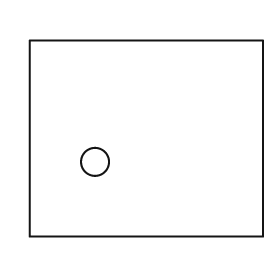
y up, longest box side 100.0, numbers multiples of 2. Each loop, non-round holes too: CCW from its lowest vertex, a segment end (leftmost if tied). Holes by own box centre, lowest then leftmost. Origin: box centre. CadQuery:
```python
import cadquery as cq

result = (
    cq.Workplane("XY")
    .moveTo(-50.0, -42.0)
    .lineTo(50.0, -42.0)
    .lineTo(50.0, 42.0)
    .lineTo(-50.0, 42.0)
    .close()
    .moveTo(-22.0, -10.0)
    .circle(6.0)
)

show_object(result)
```